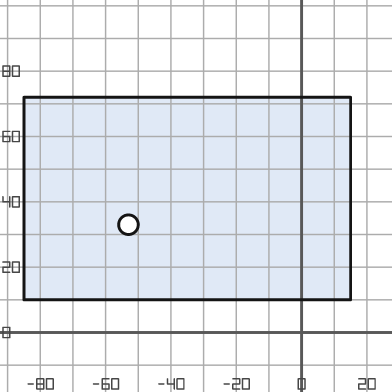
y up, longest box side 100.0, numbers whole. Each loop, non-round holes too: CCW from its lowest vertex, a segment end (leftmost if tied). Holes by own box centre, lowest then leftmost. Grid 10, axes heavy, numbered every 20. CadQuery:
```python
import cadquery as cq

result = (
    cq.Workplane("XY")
    .moveTo(-85.0, 10.0)
    .lineTo(15.0, 10.0)
    .lineTo(15.0, 72.0)
    .lineTo(-85.0, 72.0)
    .close()
    .moveTo(-53.0, 33.0)
    .circle(3.0)
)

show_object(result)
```